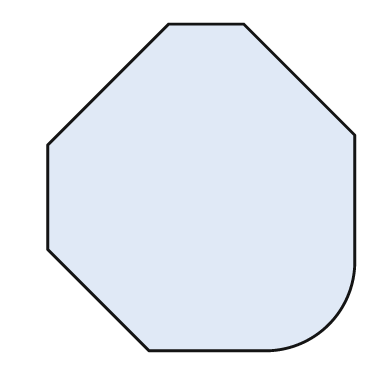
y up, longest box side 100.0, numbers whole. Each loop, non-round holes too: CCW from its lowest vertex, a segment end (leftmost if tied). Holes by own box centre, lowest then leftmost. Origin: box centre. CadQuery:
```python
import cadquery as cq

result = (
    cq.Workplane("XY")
    .moveTo(-16.0, -50.0)
    .lineTo(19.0, -50.0)
    .threePointArc((39.0, -42.0), (47.0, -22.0))
    .lineTo(47.0, 16.0)
    .lineTo(13.0, 50.0)
    .lineTo(-10.0, 50.0)
    .lineTo(-47.0, 13.0)
    .lineTo(-47.0, -19.0)
    .close()
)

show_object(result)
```